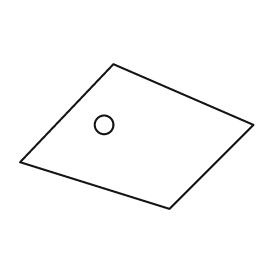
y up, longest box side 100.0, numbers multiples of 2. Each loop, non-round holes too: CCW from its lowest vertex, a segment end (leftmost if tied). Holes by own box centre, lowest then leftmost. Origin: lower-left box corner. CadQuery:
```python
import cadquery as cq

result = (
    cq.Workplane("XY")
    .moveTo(64.0, 0.0)
    .lineTo(100.0, 36.0)
    .lineTo(40.0, 62.0)
    .lineTo(0.0, 20.0)
    .close()
    .moveTo(36.0, 36.0)
    .circle(4.0)
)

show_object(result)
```